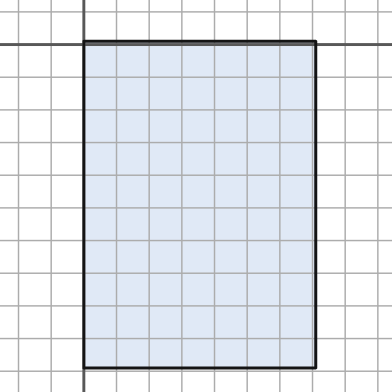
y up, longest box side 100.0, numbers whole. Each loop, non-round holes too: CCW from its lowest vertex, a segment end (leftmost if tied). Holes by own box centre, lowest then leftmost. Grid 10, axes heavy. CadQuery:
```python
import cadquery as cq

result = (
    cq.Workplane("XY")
    .moveTo(0.0, -99.0)
    .lineTo(71.0, -99.0)
    .lineTo(71.0, 1.0)
    .lineTo(0.0, 1.0)
    .close()
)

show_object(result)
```